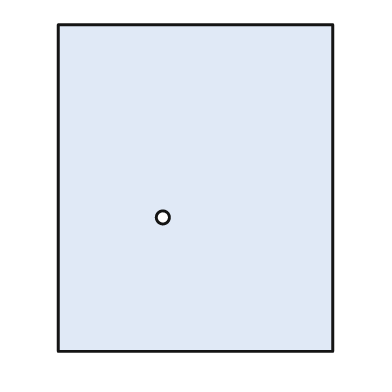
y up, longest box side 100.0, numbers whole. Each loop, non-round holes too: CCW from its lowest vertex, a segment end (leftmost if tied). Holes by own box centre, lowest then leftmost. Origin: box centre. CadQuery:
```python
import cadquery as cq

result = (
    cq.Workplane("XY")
    .moveTo(-42.0, -50.0)
    .lineTo(42.0, -50.0)
    .lineTo(42.0, 50.0)
    .lineTo(-42.0, 50.0)
    .close()
    .moveTo(-10.0, -9.0)
    .circle(2.0)
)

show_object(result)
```